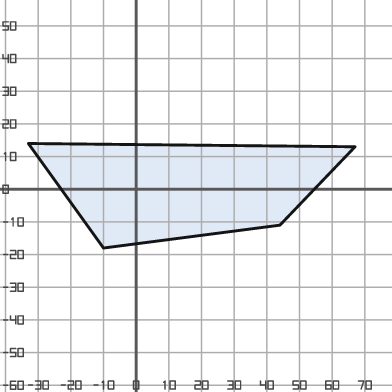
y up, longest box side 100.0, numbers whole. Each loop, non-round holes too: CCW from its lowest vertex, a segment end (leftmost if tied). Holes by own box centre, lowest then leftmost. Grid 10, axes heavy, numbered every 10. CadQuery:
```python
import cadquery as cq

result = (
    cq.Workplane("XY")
    .moveTo(-10.0, -18.0)
    .lineTo(44.0, -11.0)
    .lineTo(67.0, 13.0)
    .lineTo(-33.0, 14.0)
    .close()
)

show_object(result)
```